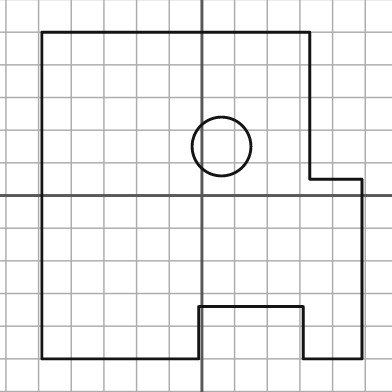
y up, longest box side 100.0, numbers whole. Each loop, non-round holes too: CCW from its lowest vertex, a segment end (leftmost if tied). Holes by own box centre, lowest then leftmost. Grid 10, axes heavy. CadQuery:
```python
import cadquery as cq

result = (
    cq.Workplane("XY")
    .moveTo(-49.0, -50.0)
    .lineTo(-1.0, -50.0)
    .lineTo(-1.0, -34.0)
    .lineTo(31.0, -34.0)
    .lineTo(31.0, -50.0)
    .lineTo(49.0, -50.0)
    .lineTo(49.0, 5.0)
    .lineTo(33.0, 5.0)
    .lineTo(33.0, 50.0)
    .lineTo(-49.0, 50.0)
    .close()
    .moveTo(6.0, 15.0)
    .circle(9.0)
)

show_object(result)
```